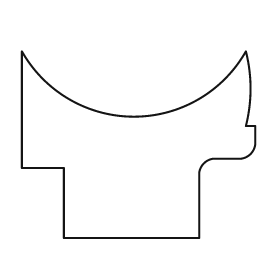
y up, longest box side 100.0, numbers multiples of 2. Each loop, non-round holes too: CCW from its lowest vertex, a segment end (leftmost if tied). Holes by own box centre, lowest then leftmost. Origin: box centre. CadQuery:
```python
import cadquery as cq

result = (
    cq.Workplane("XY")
    .moveTo(-32.0, -40.0)
    .lineTo(26.0, -40.0)
    .lineTo(26.0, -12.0)
    .threePointArc((28.0, -8.0), (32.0, -6.0))
    .lineTo(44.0, -6.0)
    .threePointArc((48.0, -4.0), (50.0, 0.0))
    .lineTo(50.0, 8.0)
    .lineTo(46.0, 8.0)
    .threePointArc((48.0, 24.0), (46.0, 40.0))
    .threePointArc((-2.0, 12.0), (-50.0, 40.0))
    .lineTo(-50.0, -10.0)
    .lineTo(-32.0, -10.0)
    .close()
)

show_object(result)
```